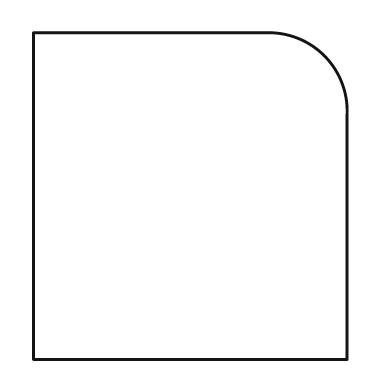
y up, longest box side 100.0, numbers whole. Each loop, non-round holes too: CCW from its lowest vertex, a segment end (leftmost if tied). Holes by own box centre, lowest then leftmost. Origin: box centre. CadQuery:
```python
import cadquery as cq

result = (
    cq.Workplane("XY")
    .moveTo(-48.0, -50.0)
    .lineTo(48.0, -50.0)
    .lineTo(48.0, 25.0)
    .threePointArc((41.0, 43.0), (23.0, 50.0))
    .lineTo(-48.0, 50.0)
    .close()
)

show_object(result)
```